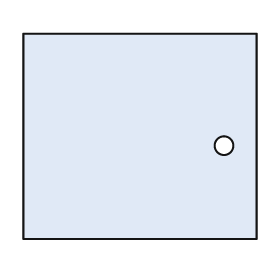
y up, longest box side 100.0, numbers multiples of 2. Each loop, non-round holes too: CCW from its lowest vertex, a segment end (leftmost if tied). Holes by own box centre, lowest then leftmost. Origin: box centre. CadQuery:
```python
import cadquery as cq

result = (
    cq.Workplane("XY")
    .moveTo(-50.0, -44.0)
    .lineTo(50.0, -44.0)
    .lineTo(50.0, 44.0)
    .lineTo(-50.0, 44.0)
    .close()
    .moveTo(36.0, -4.0)
    .circle(4.0)
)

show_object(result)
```